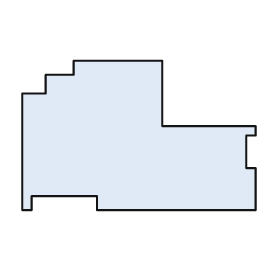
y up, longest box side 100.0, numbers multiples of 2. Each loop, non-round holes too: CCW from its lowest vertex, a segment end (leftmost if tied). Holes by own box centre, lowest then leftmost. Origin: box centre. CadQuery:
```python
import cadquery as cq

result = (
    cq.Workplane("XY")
    .moveTo(-50.0, -32.0)
    .lineTo(-46.0, -32.0)
    .lineTo(-46.0, -26.0)
    .lineTo(-18.0, -26.0)
    .lineTo(-18.0, -32.0)
    .lineTo(50.0, -32.0)
    .lineTo(50.0, -14.0)
    .lineTo(46.0, -14.0)
    .lineTo(46.0, 0.0)
    .lineTo(50.0, 0.0)
    .lineTo(50.0, 4.0)
    .lineTo(10.0, 4.0)
    .lineTo(10.0, 32.0)
    .lineTo(-28.0, 32.0)
    .lineTo(-28.0, 26.0)
    .lineTo(-40.0, 26.0)
    .lineTo(-40.0, 18.0)
    .lineTo(-50.0, 18.0)
    .close()
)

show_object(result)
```